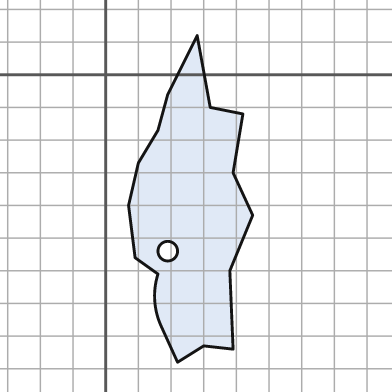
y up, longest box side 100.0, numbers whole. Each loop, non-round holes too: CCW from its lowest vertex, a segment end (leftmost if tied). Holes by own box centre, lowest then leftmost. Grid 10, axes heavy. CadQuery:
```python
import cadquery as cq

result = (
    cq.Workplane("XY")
    .moveTo(22.0, -88.0)
    .lineTo(30.0, -83.0)
    .lineTo(39.0, -84.0)
    .lineTo(38.0, -60.0)
    .lineTo(45.0, -43.0)
    .lineTo(39.0, -30.0)
    .lineTo(42.0, -12.0)
    .lineTo(32.0, -10.0)
    .lineTo(28.0, 12.0)
    .lineTo(19.0, -6.0)
    .lineTo(16.0, -17.0)
    .lineTo(10.0, -27.0)
    .lineTo(7.0, -40.0)
    .lineTo(9.0, -56.0)
    .lineTo(16.0, -61.0)
    .threePointArc((15.0, -69.0), (17.0, -77.0))
    .close()
    .moveTo(19.0, -54.0)
    .circle(3.0)
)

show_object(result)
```